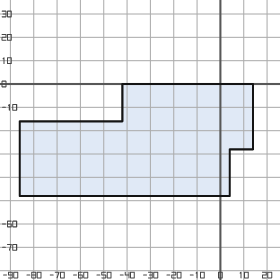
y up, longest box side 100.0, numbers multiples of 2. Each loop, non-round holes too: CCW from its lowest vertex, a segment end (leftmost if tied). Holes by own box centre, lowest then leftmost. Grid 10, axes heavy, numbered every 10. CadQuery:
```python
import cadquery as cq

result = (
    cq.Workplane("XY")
    .moveTo(-86.0, -48.0)
    .lineTo(4.0, -48.0)
    .lineTo(4.0, -28.0)
    .lineTo(14.0, -28.0)
    .lineTo(14.0, 0.0)
    .lineTo(-42.0, 0.0)
    .lineTo(-42.0, -16.0)
    .lineTo(-86.0, -16.0)
    .close()
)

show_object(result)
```